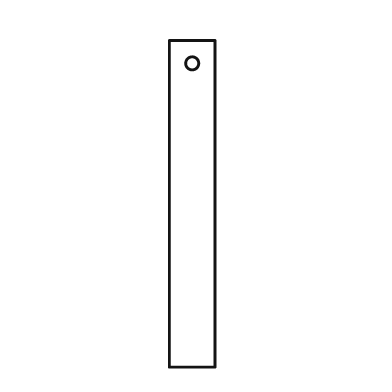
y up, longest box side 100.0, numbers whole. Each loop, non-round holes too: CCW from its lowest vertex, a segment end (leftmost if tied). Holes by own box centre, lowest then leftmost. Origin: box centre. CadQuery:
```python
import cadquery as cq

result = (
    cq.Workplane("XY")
    .moveTo(-7.0, -50.0)
    .lineTo(7.0, -50.0)
    .lineTo(7.0, 50.0)
    .lineTo(-7.0, 50.0)
    .close()
    .moveTo(0.0, 43.0)
    .circle(2.0)
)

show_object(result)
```